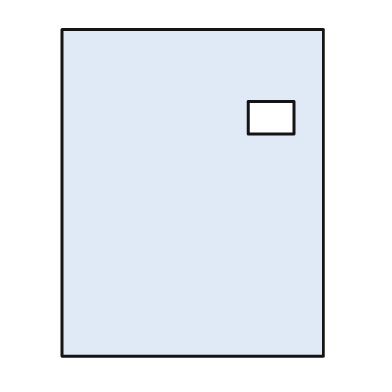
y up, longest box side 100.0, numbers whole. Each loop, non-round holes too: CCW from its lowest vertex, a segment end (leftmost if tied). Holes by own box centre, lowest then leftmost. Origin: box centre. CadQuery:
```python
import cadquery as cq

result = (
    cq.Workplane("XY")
    .moveTo(-40.0, -50.0)
    .lineTo(40.0, -50.0)
    .lineTo(40.0, 50.0)
    .lineTo(-40.0, 50.0)
    .close()
    .moveTo(17.0, 18.0)
    .lineTo(31.0, 18.0)
    .lineTo(31.0, 28.0)
    .lineTo(17.0, 28.0)
    .close()
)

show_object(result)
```